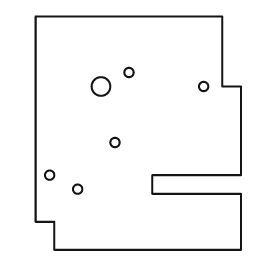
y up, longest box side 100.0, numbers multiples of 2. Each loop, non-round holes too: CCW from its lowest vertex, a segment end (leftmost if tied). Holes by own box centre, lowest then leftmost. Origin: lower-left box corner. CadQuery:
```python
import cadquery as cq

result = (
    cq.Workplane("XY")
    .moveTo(8.0, 0.0)
    .lineTo(88.0, 0.0)
    .lineTo(88.0, 24.0)
    .lineTo(50.0, 24.0)
    .lineTo(50.0, 32.0)
    .lineTo(88.0, 32.0)
    .lineTo(88.0, 70.0)
    .lineTo(80.0, 70.0)
    .lineTo(80.0, 100.0)
    .lineTo(0.0, 100.0)
    .lineTo(0.0, 12.0)
    .lineTo(8.0, 12.0)
    .close()
    .moveTo(18.0, 26.0)
    .circle(2.0)
    .moveTo(6.0, 32.0)
    .circle(2.0)
    .moveTo(34.0, 46.0)
    .circle(2.0)
    .moveTo(28.0, 70.0)
    .circle(4.0)
    .moveTo(72.0, 70.0)
    .circle(2.0)
    .moveTo(40.0, 76.0)
    .circle(2.0)
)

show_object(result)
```